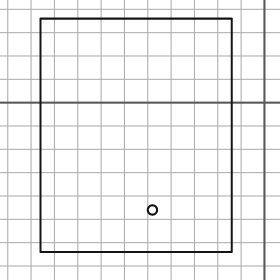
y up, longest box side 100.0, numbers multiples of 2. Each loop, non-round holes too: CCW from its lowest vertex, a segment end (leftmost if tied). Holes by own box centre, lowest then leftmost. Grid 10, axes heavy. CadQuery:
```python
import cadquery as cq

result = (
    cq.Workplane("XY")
    .moveTo(-96.0, -64.0)
    .lineTo(-14.0, -64.0)
    .lineTo(-14.0, 36.0)
    .lineTo(-96.0, 36.0)
    .close()
    .moveTo(-48.0, -46.0)
    .circle(2.0)
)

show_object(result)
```